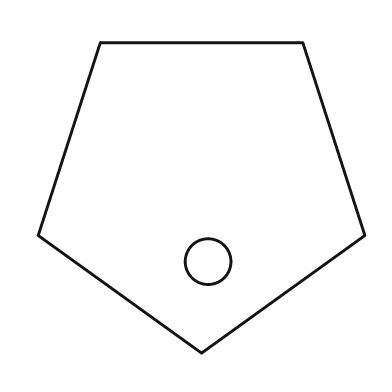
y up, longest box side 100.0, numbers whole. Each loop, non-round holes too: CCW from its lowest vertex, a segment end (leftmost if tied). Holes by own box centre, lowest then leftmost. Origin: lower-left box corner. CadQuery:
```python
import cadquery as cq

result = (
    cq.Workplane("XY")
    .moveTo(50.0, 0.0)
    .lineTo(100.0, 36.0)
    .lineTo(81.0, 95.0)
    .lineTo(19.0, 95.0)
    .lineTo(0.0, 36.0)
    .close()
    .moveTo(52.0, 28.0)
    .circle(7.0)
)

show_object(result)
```